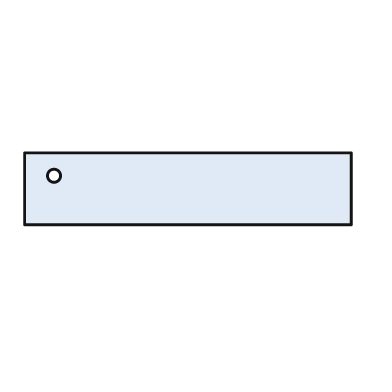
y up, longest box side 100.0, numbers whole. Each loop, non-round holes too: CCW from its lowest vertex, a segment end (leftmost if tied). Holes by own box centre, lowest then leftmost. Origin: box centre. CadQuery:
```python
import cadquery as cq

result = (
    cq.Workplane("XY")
    .moveTo(-50.0, -11.0)
    .lineTo(50.0, -11.0)
    .lineTo(50.0, 11.0)
    .lineTo(-50.0, 11.0)
    .close()
    .moveTo(-41.0, 4.0)
    .circle(2.0)
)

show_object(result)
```